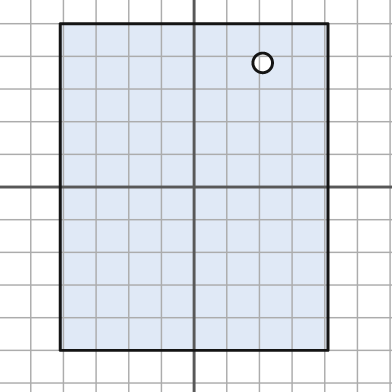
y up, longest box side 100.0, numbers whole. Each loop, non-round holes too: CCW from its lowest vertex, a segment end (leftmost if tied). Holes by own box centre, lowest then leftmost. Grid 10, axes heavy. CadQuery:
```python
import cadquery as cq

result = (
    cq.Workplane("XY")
    .moveTo(-41.0, -50.0)
    .lineTo(41.0, -50.0)
    .lineTo(41.0, 50.0)
    .lineTo(-41.0, 50.0)
    .close()
    .moveTo(21.0, 38.0)
    .circle(3.0)
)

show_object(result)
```